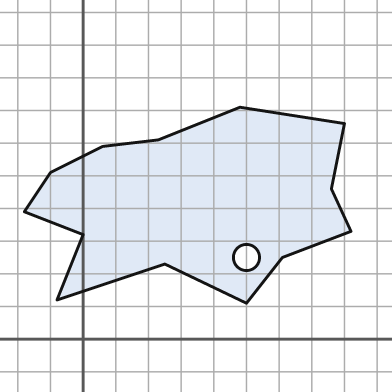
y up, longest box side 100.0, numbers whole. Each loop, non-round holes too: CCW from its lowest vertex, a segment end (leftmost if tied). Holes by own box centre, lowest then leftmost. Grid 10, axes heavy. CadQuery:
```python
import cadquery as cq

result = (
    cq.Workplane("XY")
    .moveTo(50.0, 11.0)
    .lineTo(61.0, 25.0)
    .lineTo(82.0, 33.0)
    .lineTo(76.0, 46.0)
    .lineTo(80.0, 66.0)
    .lineTo(48.0, 71.0)
    .lineTo(23.0, 61.0)
    .lineTo(6.0, 59.0)
    .lineTo(-10.0, 51.0)
    .lineTo(-18.0, 39.0)
    .lineTo(0.0, 32.0)
    .lineTo(-8.0, 12.0)
    .lineTo(25.0, 23.0)
    .close()
    .moveTo(50.0, 25.0)
    .circle(4.0)
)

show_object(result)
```